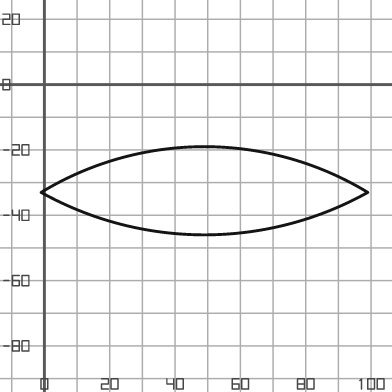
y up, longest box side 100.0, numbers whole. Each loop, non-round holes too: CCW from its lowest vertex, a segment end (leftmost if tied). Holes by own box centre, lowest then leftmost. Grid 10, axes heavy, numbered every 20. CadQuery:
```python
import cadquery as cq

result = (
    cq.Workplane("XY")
    .moveTo(-1.0, -33.0)
    .threePointArc((49.0, -46.0), (99.0, -33.0))
    .threePointArc((49.0, -19.0), (-1.0, -33.0))
    .close()
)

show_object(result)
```